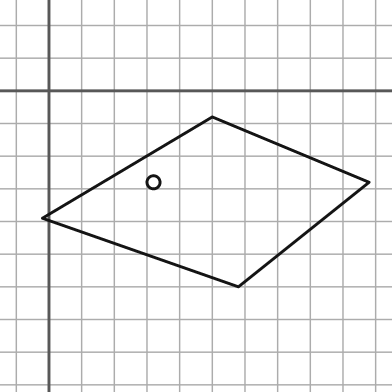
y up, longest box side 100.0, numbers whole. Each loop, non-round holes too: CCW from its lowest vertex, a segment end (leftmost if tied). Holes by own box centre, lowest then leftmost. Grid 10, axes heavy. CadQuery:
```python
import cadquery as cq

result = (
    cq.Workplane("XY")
    .moveTo(58.0, -60.0)
    .lineTo(98.0, -28.0)
    .lineTo(50.0, -8.0)
    .lineTo(-2.0, -39.0)
    .close()
    .moveTo(32.0, -28.0)
    .circle(2.0)
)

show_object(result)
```